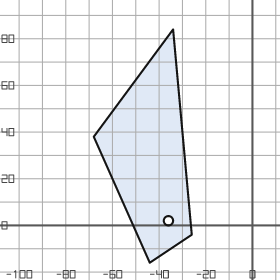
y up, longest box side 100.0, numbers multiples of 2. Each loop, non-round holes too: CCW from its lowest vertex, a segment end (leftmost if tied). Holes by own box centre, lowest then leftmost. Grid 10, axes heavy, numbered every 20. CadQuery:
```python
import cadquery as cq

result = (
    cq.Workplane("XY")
    .moveTo(-44.0, -16.0)
    .lineTo(-26.0, -4.0)
    .lineTo(-34.0, 84.0)
    .lineTo(-68.0, 38.0)
    .close()
    .moveTo(-36.0, 2.0)
    .circle(2.0)
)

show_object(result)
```